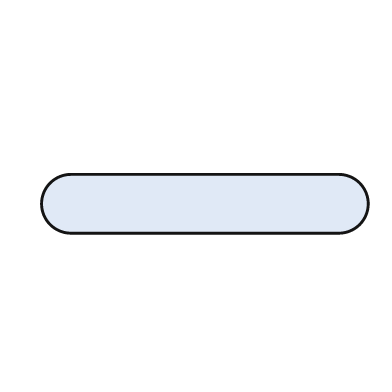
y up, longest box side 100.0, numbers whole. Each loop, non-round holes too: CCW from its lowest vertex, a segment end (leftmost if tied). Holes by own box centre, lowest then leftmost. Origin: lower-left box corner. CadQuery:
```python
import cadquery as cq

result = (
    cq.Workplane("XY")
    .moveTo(9.0, 0.0)
    .lineTo(91.0, 0.0)
    .threePointArc((100.0, 9.0), (91.0, 18.0))
    .lineTo(9.0, 18.0)
    .threePointArc((0.0, 9.0), (9.0, 0.0))
    .close()
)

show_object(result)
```